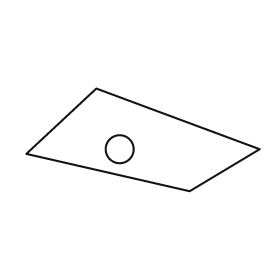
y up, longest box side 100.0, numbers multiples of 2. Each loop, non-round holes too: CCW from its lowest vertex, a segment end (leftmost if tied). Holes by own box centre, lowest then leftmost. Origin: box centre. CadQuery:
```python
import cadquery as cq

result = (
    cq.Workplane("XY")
    .moveTo(20.0, -22.0)
    .lineTo(50.0, -4.0)
    .lineTo(-20.0, 22.0)
    .lineTo(-50.0, -6.0)
    .close()
    .moveTo(-10.0, -4.0)
    .circle(6.0)
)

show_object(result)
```